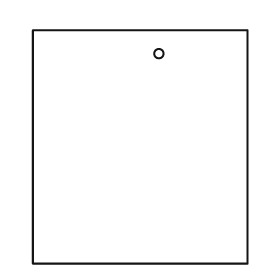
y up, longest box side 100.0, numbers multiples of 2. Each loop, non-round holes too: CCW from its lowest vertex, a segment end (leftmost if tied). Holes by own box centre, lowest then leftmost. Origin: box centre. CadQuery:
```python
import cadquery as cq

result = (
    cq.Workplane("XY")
    .moveTo(-46.0, -50.0)
    .lineTo(46.0, -50.0)
    .lineTo(46.0, 50.0)
    .lineTo(-46.0, 50.0)
    .close()
    .moveTo(8.0, 40.0)
    .circle(2.0)
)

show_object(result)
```